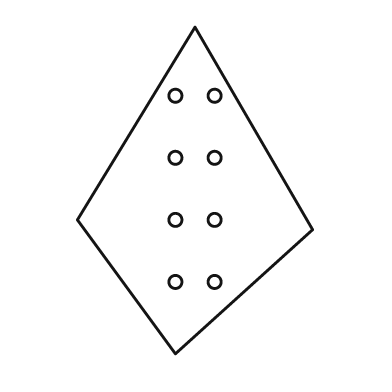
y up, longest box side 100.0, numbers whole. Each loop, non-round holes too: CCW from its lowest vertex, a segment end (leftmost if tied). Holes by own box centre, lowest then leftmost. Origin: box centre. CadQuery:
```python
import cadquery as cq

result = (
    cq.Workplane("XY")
    .moveTo(-6.0, -50.0)
    .lineTo(36.0, -12.0)
    .lineTo(0.0, 50.0)
    .lineTo(-36.0, -9.0)
    .close()
    .moveTo(-6.0, -28.0)
    .circle(2.0)
    .moveTo(6.0, -28.0)
    .circle(2.0)
    .moveTo(-6.0, -9.0)
    .circle(2.0)
    .moveTo(6.0, -9.0)
    .circle(2.0)
    .moveTo(-6.0, 10.0)
    .circle(2.0)
    .moveTo(6.0, 10.0)
    .circle(2.0)
    .moveTo(-6.0, 29.0)
    .circle(2.0)
    .moveTo(6.0, 29.0)
    .circle(2.0)
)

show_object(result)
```